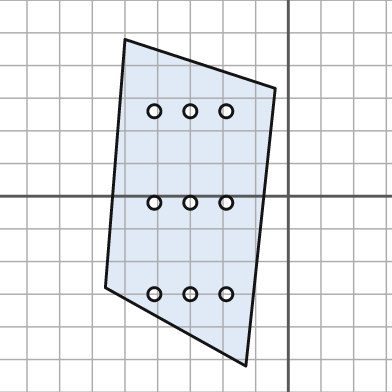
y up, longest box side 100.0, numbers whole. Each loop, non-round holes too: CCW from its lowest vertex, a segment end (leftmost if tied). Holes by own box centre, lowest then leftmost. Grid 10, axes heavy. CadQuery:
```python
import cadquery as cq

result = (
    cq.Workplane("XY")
    .moveTo(-13.0, -52.0)
    .lineTo(-4.0, 33.0)
    .lineTo(-50.0, 48.0)
    .lineTo(-56.0, -28.0)
    .close()
    .moveTo(-41.0, -30.0)
    .circle(2.0)
    .moveTo(-30.0, -30.0)
    .circle(2.0)
    .moveTo(-19.0, -30.0)
    .circle(2.0)
    .moveTo(-41.0, -2.0)
    .circle(2.0)
    .moveTo(-30.0, -2.0)
    .circle(2.0)
    .moveTo(-19.0, -2.0)
    .circle(2.0)
    .moveTo(-41.0, 26.0)
    .circle(2.0)
    .moveTo(-30.0, 26.0)
    .circle(2.0)
    .moveTo(-19.0, 26.0)
    .circle(2.0)
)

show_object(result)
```